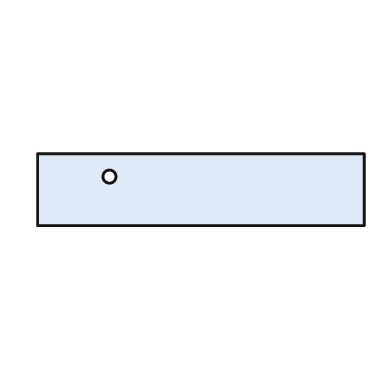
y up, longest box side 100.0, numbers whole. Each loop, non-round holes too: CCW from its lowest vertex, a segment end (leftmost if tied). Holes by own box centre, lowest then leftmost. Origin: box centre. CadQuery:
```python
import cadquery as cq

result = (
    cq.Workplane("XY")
    .moveTo(-50.0, -11.0)
    .lineTo(50.0, -11.0)
    .lineTo(50.0, 11.0)
    .lineTo(-50.0, 11.0)
    .close()
    .moveTo(-28.0, 4.0)
    .circle(2.0)
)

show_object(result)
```